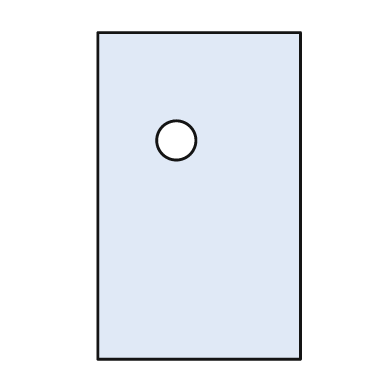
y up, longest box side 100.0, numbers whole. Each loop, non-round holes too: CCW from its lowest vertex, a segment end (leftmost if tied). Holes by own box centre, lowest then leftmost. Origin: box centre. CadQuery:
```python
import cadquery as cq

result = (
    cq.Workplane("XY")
    .moveTo(-31.0, -50.0)
    .lineTo(31.0, -50.0)
    .lineTo(31.0, 50.0)
    .lineTo(-31.0, 50.0)
    .close()
    .moveTo(-7.0, 17.0)
    .circle(6.0)
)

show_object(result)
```